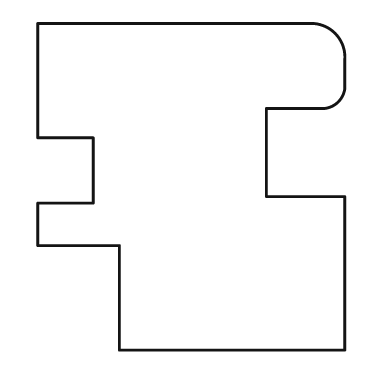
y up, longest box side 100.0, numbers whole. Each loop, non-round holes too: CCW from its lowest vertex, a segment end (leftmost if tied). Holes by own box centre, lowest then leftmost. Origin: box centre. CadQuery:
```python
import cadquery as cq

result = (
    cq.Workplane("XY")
    .moveTo(-22.0, -50.0)
    .lineTo(47.0, -50.0)
    .lineTo(47.0, -3.0)
    .lineTo(23.0, -3.0)
    .lineTo(23.0, 24.0)
    .lineTo(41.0, 24.0)
    .threePointArc((45.0, 26.0), (47.0, 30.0))
    .lineTo(47.0, 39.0)
    .threePointArc((44.0, 47.0), (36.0, 50.0))
    .lineTo(-47.0, 50.0)
    .lineTo(-47.0, 15.0)
    .lineTo(-30.0, 15.0)
    .lineTo(-30.0, -5.0)
    .lineTo(-47.0, -5.0)
    .lineTo(-47.0, -18.0)
    .lineTo(-22.0, -18.0)
    .close()
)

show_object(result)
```